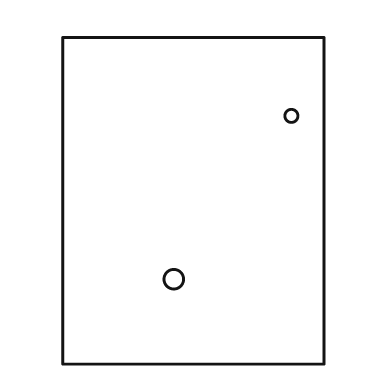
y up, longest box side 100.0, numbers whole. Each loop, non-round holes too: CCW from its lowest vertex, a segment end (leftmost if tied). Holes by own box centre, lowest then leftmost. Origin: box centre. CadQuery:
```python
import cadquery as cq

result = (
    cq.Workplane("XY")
    .moveTo(-40.0, -50.0)
    .lineTo(40.0, -50.0)
    .lineTo(40.0, 50.0)
    .lineTo(-40.0, 50.0)
    .close()
    .moveTo(-6.0, -24.0)
    .circle(3.0)
    .moveTo(30.0, 26.0)
    .circle(2.0)
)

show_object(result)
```